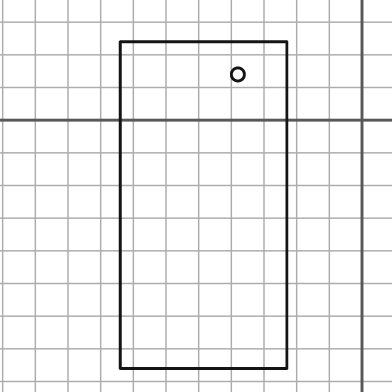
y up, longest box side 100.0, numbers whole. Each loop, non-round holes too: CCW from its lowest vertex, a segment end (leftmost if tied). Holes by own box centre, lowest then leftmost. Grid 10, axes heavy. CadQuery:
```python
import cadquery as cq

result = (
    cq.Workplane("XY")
    .moveTo(-74.0, -76.0)
    .lineTo(-23.0, -76.0)
    .lineTo(-23.0, 24.0)
    .lineTo(-74.0, 24.0)
    .close()
    .moveTo(-38.0, 14.0)
    .circle(2.0)
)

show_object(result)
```